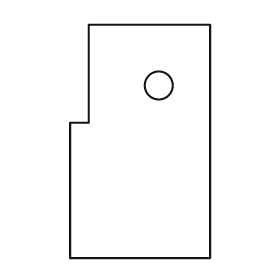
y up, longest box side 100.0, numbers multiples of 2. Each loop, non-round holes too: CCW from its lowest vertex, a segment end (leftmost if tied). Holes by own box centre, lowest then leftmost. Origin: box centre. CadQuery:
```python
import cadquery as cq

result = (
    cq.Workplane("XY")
    .moveTo(-30.0, -50.0)
    .lineTo(30.0, -50.0)
    .lineTo(30.0, 50.0)
    .lineTo(-22.0, 50.0)
    .lineTo(-22.0, 8.0)
    .lineTo(-30.0, 8.0)
    .close()
    .moveTo(8.0, 24.0)
    .circle(6.0)
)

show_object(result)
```